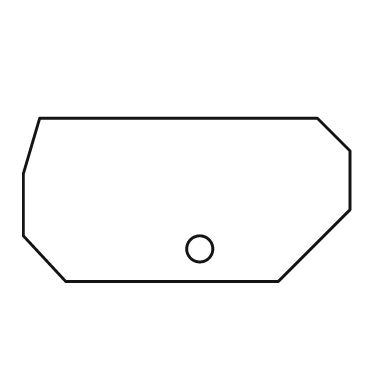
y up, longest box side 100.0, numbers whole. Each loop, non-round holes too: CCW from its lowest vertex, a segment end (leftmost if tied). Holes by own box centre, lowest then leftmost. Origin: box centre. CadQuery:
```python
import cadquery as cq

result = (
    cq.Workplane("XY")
    .moveTo(-37.0, -25.0)
    .lineTo(28.0, -25.0)
    .lineTo(50.0, -3.0)
    .lineTo(50.0, 15.0)
    .lineTo(40.0, 25.0)
    .lineTo(-45.0, 25.0)
    .lineTo(-50.0, 8.0)
    .lineTo(-50.0, -11.0)
    .close()
    .moveTo(4.0, -15.0)
    .circle(4.0)
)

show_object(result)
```